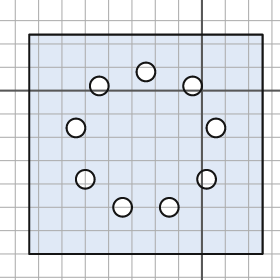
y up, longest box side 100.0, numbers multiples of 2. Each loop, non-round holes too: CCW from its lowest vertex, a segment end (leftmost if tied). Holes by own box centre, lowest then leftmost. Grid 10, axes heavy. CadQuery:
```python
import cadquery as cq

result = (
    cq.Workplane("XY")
    .moveTo(-74.0, -70.0)
    .lineTo(26.0, -70.0)
    .lineTo(26.0, 24.0)
    .lineTo(-74.0, 24.0)
    .close()
    .moveTo(-34.0, -50.0)
    .circle(4.0)
    .moveTo(-14.0, -50.0)
    .circle(4.0)
    .moveTo(-50.0, -38.0)
    .circle(4.0)
    .moveTo(2.0, -38.0)
    .circle(4.0)
    .moveTo(-54.0, -16.0)
    .circle(4.0)
    .moveTo(6.0, -16.0)
    .circle(4.0)
    .moveTo(-44.0, 2.0)
    .circle(4.0)
    .moveTo(-4.0, 2.0)
    .circle(4.0)
    .moveTo(-24.0, 8.0)
    .circle(4.0)
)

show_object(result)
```